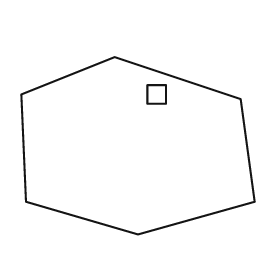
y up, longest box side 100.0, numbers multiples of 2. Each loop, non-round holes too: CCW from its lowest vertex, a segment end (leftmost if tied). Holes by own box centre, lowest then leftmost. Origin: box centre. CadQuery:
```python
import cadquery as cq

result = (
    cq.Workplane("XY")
    .moveTo(0.0, -38.0)
    .lineTo(50.0, -24.0)
    .lineTo(44.0, 20.0)
    .lineTo(-10.0, 38.0)
    .lineTo(-50.0, 22.0)
    .lineTo(-48.0, -24.0)
    .close()
    .moveTo(4.0, 18.0)
    .lineTo(12.0, 18.0)
    .lineTo(12.0, 26.0)
    .lineTo(4.0, 26.0)
    .close()
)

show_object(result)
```